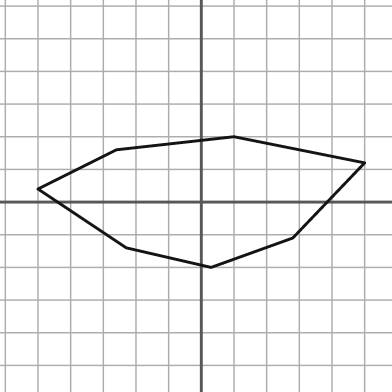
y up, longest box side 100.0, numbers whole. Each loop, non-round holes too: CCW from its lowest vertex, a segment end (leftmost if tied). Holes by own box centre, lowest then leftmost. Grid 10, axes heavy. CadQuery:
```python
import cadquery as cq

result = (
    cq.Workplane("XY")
    .moveTo(3.0, -20.0)
    .lineTo(28.0, -11.0)
    .lineTo(50.0, 12.0)
    .lineTo(10.0, 20.0)
    .lineTo(-26.0, 16.0)
    .lineTo(-50.0, 4.0)
    .lineTo(-23.0, -14.0)
    .close()
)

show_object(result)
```